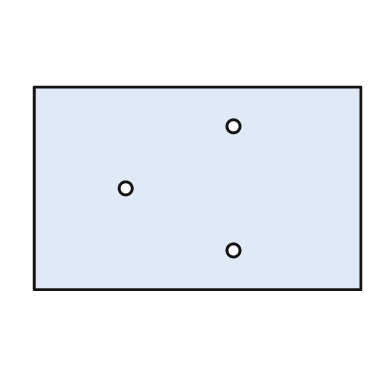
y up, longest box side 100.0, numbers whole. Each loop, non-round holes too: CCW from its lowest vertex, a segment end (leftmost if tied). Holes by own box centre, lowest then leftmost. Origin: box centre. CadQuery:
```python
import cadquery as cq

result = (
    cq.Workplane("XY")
    .moveTo(-50.0, -31.0)
    .lineTo(50.0, -31.0)
    .lineTo(50.0, 31.0)
    .lineTo(-50.0, 31.0)
    .close()
    .moveTo(11.0, -19.0)
    .circle(2.0)
    .moveTo(-22.0, 0.0)
    .circle(2.0)
    .moveTo(11.0, 19.0)
    .circle(2.0)
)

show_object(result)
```